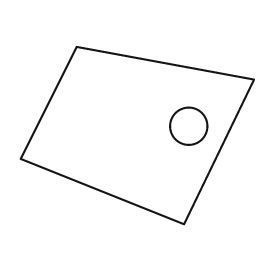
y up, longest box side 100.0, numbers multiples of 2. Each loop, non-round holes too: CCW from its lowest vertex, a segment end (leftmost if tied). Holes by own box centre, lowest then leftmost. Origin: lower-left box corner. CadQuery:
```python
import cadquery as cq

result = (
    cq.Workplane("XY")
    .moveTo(70.0, 0.0)
    .lineTo(100.0, 62.0)
    .lineTo(24.0, 76.0)
    .lineTo(0.0, 28.0)
    .close()
    .moveTo(72.0, 42.0)
    .circle(8.0)
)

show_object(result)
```